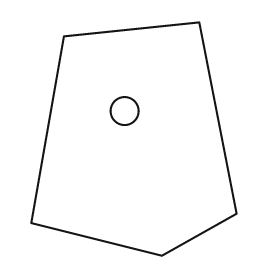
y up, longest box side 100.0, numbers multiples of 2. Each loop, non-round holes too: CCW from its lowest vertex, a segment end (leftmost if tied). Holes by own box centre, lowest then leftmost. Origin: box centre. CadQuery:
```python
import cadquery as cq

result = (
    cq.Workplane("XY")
    .moveTo(12.0, -50.0)
    .lineTo(44.0, -32.0)
    .lineTo(28.0, 50.0)
    .lineTo(-30.0, 44.0)
    .lineTo(-44.0, -36.0)
    .close()
    .moveTo(-4.0, 12.0)
    .circle(6.0)
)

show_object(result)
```